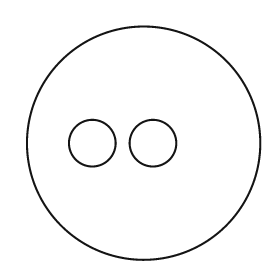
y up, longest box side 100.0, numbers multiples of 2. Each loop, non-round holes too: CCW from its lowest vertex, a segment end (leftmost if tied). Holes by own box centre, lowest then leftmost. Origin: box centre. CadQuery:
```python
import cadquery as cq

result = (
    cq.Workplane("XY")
    .moveTo(0.0, 0.0)
    .circle(50.0)
    .moveTo(-22.0, 0.0)
    .circle(10.0)
    .moveTo(4.0, 0.0)
    .circle(10.0)
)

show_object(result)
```